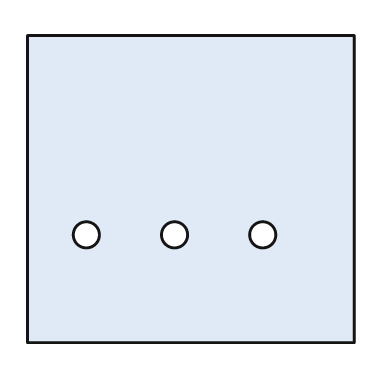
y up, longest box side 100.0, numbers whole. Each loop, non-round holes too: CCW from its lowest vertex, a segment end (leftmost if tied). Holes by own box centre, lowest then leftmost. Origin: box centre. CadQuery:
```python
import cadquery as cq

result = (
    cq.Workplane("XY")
    .moveTo(-50.0, -47.0)
    .lineTo(50.0, -47.0)
    .lineTo(50.0, 47.0)
    .lineTo(-50.0, 47.0)
    .close()
    .moveTo(-32.0, -14.0)
    .circle(4.0)
    .moveTo(-5.0, -14.0)
    .circle(4.0)
    .moveTo(22.0, -14.0)
    .circle(4.0)
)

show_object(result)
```